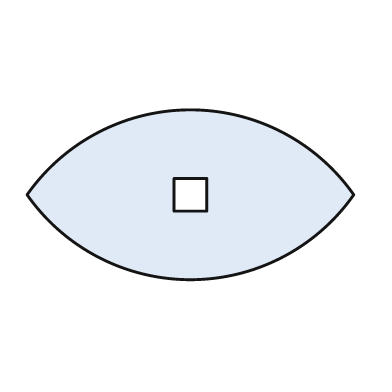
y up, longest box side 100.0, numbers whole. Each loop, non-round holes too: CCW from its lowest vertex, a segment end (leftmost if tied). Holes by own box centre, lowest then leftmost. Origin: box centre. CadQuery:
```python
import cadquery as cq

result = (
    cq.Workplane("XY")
    .moveTo(-50.0, 0.0)
    .threePointArc((0.0, -26.0), (50.0, 0.0))
    .threePointArc((0.0, 26.0), (-50.0, 0.0))
    .close()
    .moveTo(-5.0, -5.0)
    .lineTo(5.0, -5.0)
    .lineTo(5.0, 5.0)
    .lineTo(-5.0, 5.0)
    .close()
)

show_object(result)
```